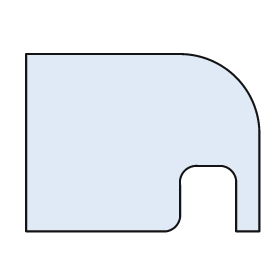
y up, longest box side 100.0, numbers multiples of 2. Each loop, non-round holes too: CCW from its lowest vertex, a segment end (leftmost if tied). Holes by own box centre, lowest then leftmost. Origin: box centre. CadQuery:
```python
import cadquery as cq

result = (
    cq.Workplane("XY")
    .moveTo(-50.0, -38.0)
    .lineTo(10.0, -38.0)
    .threePointArc((14.0, -36.0), (16.0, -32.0))
    .lineTo(16.0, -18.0)
    .threePointArc((18.0, -12.0), (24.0, -10.0))
    .lineTo(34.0, -10.0)
    .threePointArc((38.0, -12.0), (40.0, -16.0))
    .lineTo(40.0, -38.0)
    .lineTo(50.0, -38.0)
    .lineTo(50.0, 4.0)
    .threePointArc((40.0, 28.0), (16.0, 38.0))
    .lineTo(-50.0, 38.0)
    .close()
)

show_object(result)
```